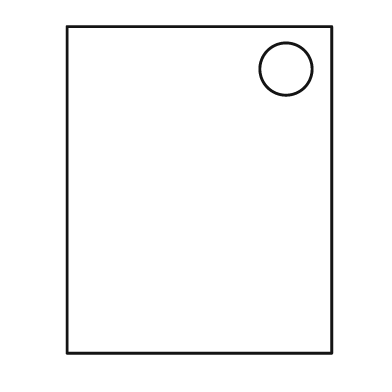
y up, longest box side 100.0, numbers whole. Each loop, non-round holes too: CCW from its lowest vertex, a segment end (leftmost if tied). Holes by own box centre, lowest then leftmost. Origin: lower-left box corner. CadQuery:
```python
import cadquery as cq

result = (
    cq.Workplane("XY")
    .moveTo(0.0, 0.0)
    .lineTo(81.0, 0.0)
    .lineTo(81.0, 100.0)
    .lineTo(0.0, 100.0)
    .close()
    .moveTo(67.0, 87.0)
    .circle(8.0)
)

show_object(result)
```